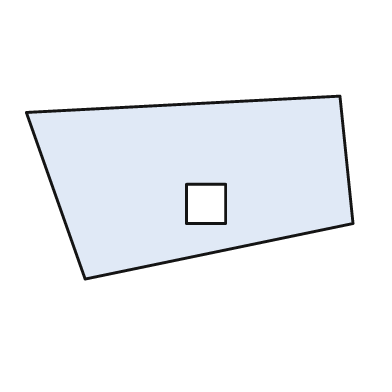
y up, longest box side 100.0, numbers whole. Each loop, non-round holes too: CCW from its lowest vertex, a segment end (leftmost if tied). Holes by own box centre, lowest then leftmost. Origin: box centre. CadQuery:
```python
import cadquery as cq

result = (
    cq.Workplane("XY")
    .moveTo(-32.0, -28.0)
    .lineTo(50.0, -11.0)
    .lineTo(46.0, 28.0)
    .lineTo(-50.0, 23.0)
    .close()
    .moveTo(-1.0, -11.0)
    .lineTo(11.0, -11.0)
    .lineTo(11.0, 1.0)
    .lineTo(-1.0, 1.0)
    .close()
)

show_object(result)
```